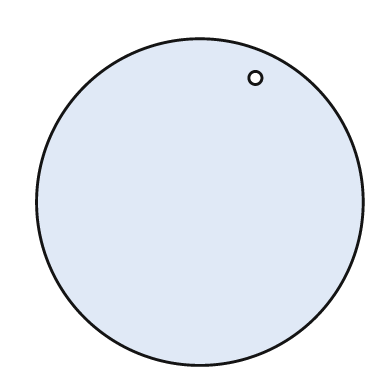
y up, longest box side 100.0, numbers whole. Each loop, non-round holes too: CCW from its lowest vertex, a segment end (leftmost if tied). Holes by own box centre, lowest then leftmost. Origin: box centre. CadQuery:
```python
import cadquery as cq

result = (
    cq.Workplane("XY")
    .moveTo(0.0, 0.0)
    .circle(50.0)
    .moveTo(17.0, 38.0)
    .circle(2.0)
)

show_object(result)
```